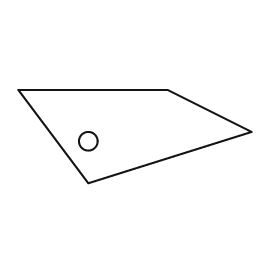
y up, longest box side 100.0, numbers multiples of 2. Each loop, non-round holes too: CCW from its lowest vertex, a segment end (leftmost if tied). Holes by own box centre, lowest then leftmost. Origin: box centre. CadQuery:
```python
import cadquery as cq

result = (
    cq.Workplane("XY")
    .moveTo(-20.0, -20.0)
    .lineTo(50.0, 2.0)
    .lineTo(14.0, 20.0)
    .lineTo(-50.0, 20.0)
    .close()
    .moveTo(-20.0, -2.0)
    .circle(4.0)
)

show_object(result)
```